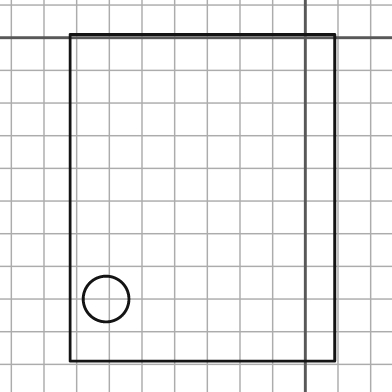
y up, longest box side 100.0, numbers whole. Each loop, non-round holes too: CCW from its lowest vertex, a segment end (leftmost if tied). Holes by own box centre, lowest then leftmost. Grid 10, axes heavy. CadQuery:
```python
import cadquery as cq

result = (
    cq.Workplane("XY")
    .moveTo(-72.0, -99.0)
    .lineTo(9.0, -99.0)
    .lineTo(9.0, 1.0)
    .lineTo(-72.0, 1.0)
    .close()
    .moveTo(-61.0, -80.0)
    .circle(7.0)
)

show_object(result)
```